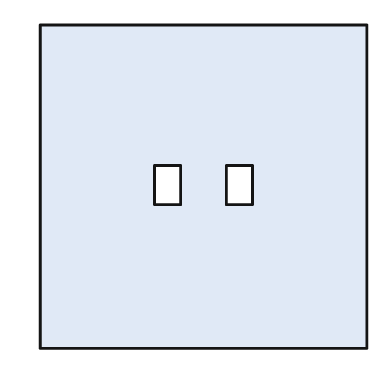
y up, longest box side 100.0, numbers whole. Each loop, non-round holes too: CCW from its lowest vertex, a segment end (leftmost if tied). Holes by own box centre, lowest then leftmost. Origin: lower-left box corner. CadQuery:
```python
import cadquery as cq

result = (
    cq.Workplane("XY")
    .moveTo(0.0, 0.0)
    .lineTo(100.0, 0.0)
    .lineTo(100.0, 99.0)
    .lineTo(0.0, 99.0)
    .close()
    .moveTo(35.0, 44.0)
    .lineTo(43.0, 44.0)
    .lineTo(43.0, 56.0)
    .lineTo(35.0, 56.0)
    .close()
    .moveTo(57.0, 44.0)
    .lineTo(65.0, 44.0)
    .lineTo(65.0, 56.0)
    .lineTo(57.0, 56.0)
    .close()
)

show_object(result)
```